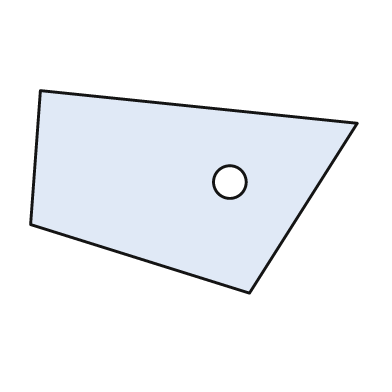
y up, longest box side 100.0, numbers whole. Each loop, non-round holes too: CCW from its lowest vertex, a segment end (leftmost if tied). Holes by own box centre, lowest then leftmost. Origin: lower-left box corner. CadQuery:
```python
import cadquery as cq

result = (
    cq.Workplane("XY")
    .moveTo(67.0, 0.0)
    .lineTo(100.0, 52.0)
    .lineTo(3.0, 62.0)
    .lineTo(0.0, 21.0)
    .close()
    .moveTo(61.0, 34.0)
    .circle(5.0)
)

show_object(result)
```